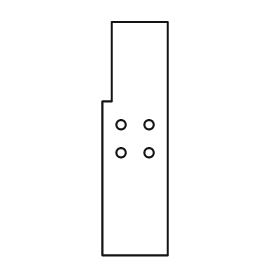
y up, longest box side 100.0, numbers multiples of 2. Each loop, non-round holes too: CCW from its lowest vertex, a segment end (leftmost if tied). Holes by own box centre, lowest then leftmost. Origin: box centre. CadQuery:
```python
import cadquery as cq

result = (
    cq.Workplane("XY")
    .moveTo(-14.0, -50.0)
    .lineTo(14.0, -50.0)
    .lineTo(14.0, 50.0)
    .lineTo(-10.0, 50.0)
    .lineTo(-10.0, 16.0)
    .lineTo(-14.0, 16.0)
    .close()
    .moveTo(-6.0, -6.0)
    .circle(2.0)
    .moveTo(6.0, -6.0)
    .circle(2.0)
    .moveTo(-6.0, 6.0)
    .circle(2.0)
    .moveTo(6.0, 6.0)
    .circle(2.0)
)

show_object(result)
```